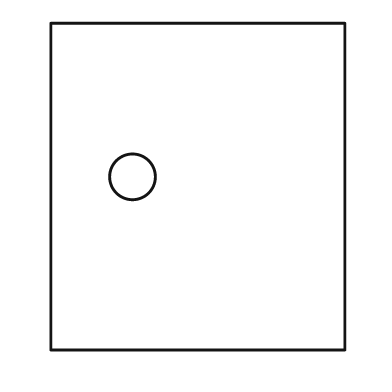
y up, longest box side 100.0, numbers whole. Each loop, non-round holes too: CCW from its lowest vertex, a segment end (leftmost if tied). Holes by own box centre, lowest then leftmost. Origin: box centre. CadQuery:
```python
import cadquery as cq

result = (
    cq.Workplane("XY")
    .moveTo(-45.0, -50.0)
    .lineTo(45.0, -50.0)
    .lineTo(45.0, 50.0)
    .lineTo(-45.0, 50.0)
    .close()
    .moveTo(-20.0, 3.0)
    .circle(7.0)
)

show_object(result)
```